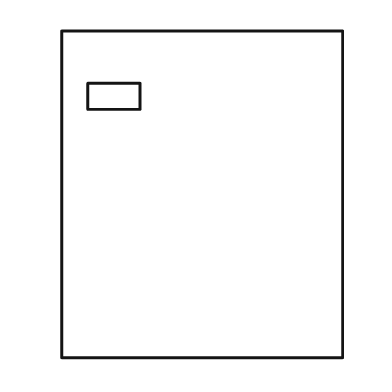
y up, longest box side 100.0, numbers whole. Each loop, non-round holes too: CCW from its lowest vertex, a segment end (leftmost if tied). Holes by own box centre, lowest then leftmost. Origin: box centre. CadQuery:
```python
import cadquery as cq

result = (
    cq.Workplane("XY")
    .moveTo(-43.0, -50.0)
    .lineTo(43.0, -50.0)
    .lineTo(43.0, 50.0)
    .lineTo(-43.0, 50.0)
    .close()
    .moveTo(-35.0, 26.0)
    .lineTo(-19.0, 26.0)
    .lineTo(-19.0, 34.0)
    .lineTo(-35.0, 34.0)
    .close()
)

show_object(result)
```